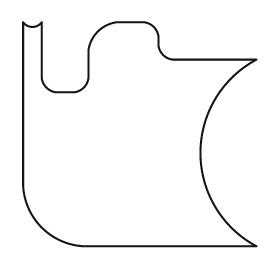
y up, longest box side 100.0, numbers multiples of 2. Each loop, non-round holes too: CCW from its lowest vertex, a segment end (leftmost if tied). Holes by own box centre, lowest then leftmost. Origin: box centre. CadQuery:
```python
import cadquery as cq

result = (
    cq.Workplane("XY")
    .moveTo(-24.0, -48.0)
    .lineTo(50.0, -48.0)
    .threePointArc((26.0, -8.0), (50.0, 32.0))
    .lineTo(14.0, 32.0)
    .threePointArc((10.0, 34.0), (8.0, 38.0))
    .lineTo(8.0, 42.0)
    .threePointArc((6.0, 46.0), (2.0, 48.0))
    .lineTo(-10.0, 48.0)
    .threePointArc((-18.0, 44.0), (-22.0, 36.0))
    .lineTo(-22.0, 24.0)
    .threePointArc((-24.0, 20.0), (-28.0, 18.0))
    .lineTo(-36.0, 18.0)
    .threePointArc((-40.0, 20.0), (-42.0, 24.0))
    .lineTo(-42.0, 48.0)
    .threePointArc((-46.0, 46.0), (-50.0, 48.0))
    .lineTo(-50.0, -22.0)
    .threePointArc((-42.0, -40.0), (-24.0, -48.0))
    .close()
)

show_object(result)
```